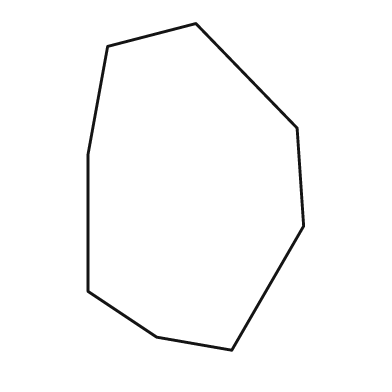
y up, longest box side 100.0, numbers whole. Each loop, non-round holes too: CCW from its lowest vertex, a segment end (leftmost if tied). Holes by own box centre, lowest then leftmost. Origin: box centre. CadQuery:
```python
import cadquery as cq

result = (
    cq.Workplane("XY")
    .moveTo(11.0, -50.0)
    .lineTo(33.0, -12.0)
    .lineTo(31.0, 18.0)
    .lineTo(0.0, 50.0)
    .lineTo(-27.0, 43.0)
    .lineTo(-33.0, 10.0)
    .lineTo(-33.0, -32.0)
    .lineTo(-12.0, -46.0)
    .close()
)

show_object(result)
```